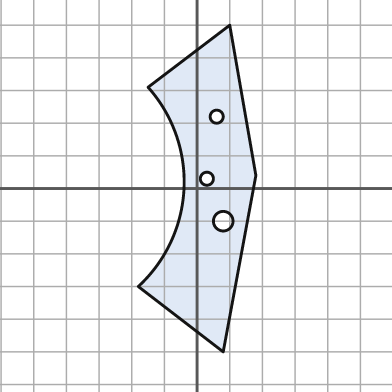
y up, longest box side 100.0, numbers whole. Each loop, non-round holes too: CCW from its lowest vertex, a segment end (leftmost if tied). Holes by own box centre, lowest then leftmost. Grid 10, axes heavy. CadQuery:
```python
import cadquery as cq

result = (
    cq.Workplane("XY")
    .moveTo(8.0, -50.0)
    .lineTo(18.0, 4.0)
    .lineTo(10.0, 50.0)
    .lineTo(-15.0, 31.0)
    .threePointArc((-4.0, 0.0), (-18.0, -30.0))
    .close()
    .moveTo(8.0, -10.0)
    .circle(3.0)
    .moveTo(3.0, 3.0)
    .circle(2.0)
    .moveTo(6.0, 22.0)
    .circle(2.0)
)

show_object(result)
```